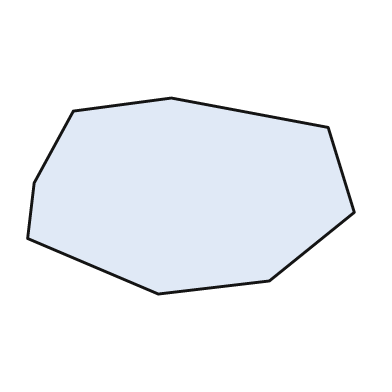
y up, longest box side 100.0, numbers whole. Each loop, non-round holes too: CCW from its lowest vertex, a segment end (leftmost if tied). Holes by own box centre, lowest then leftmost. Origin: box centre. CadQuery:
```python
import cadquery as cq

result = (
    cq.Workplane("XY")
    .moveTo(-10.0, -30.0)
    .lineTo(24.0, -26.0)
    .lineTo(50.0, -5.0)
    .lineTo(42.0, 21.0)
    .lineTo(-6.0, 30.0)
    .lineTo(-36.0, 26.0)
    .lineTo(-48.0, 4.0)
    .lineTo(-50.0, -13.0)
    .close()
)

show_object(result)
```